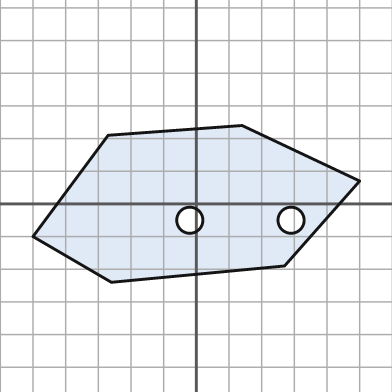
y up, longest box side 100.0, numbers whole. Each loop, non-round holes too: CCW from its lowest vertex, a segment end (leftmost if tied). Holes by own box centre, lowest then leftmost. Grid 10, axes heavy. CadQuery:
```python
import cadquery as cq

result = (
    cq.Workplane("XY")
    .moveTo(-26.0, -24.0)
    .lineTo(27.0, -19.0)
    .lineTo(50.0, 7.0)
    .lineTo(14.0, 24.0)
    .lineTo(-27.0, 21.0)
    .lineTo(-50.0, -10.0)
    .close()
    .moveTo(-2.0, -5.0)
    .circle(4.0)
    .moveTo(29.0, -5.0)
    .circle(4.0)
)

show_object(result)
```